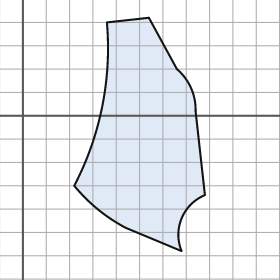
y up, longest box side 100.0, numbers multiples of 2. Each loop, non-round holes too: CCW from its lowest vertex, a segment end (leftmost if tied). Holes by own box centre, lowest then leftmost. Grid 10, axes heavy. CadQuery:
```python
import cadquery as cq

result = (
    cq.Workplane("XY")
    .moveTo(68.0, -58.0)
    .threePointArc((68.0, -44.0), (78.0, -34.0))
    .lineTo(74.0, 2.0)
    .threePointArc((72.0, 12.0), (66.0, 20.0))
    .lineTo(54.0, 42.0)
    .lineTo(36.0, 40.0)
    .threePointArc((34.0, 4.0), (22.0, -30.0))
    .threePointArc((32.0, -40.0), (44.0, -48.0))
    .close()
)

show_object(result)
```